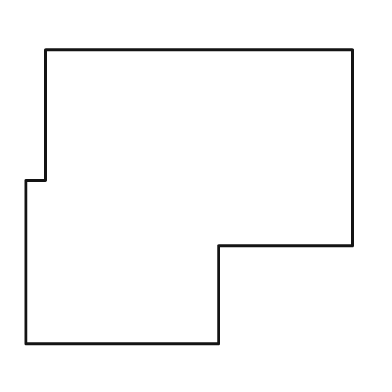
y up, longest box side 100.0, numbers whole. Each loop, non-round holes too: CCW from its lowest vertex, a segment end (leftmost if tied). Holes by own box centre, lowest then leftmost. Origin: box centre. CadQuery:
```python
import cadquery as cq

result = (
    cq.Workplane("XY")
    .moveTo(-50.0, -45.0)
    .lineTo(9.0, -45.0)
    .lineTo(9.0, -15.0)
    .lineTo(50.0, -15.0)
    .lineTo(50.0, 45.0)
    .lineTo(-44.0, 45.0)
    .lineTo(-44.0, 5.0)
    .lineTo(-50.0, 5.0)
    .close()
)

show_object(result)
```